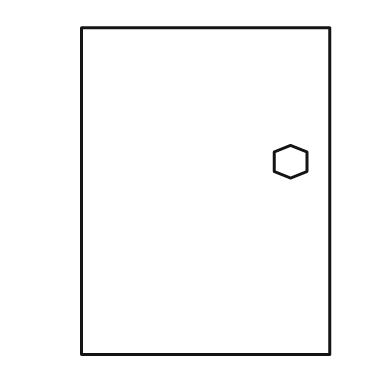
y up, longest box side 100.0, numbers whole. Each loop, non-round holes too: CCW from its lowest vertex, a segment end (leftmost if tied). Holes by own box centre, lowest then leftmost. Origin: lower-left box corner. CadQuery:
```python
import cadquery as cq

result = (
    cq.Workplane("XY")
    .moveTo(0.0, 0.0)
    .lineTo(76.0, 0.0)
    .lineTo(76.0, 100.0)
    .lineTo(0.0, 100.0)
    .close()
    .moveTo(64.0, 54.0)
    .lineTo(69.0, 56.0)
    .lineTo(69.0, 62.0)
    .lineTo(64.0, 64.0)
    .lineTo(59.0, 62.0)
    .lineTo(59.0, 56.0)
    .close()
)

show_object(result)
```